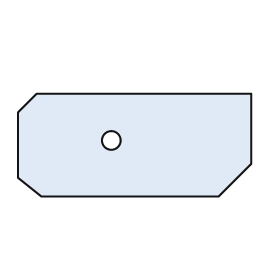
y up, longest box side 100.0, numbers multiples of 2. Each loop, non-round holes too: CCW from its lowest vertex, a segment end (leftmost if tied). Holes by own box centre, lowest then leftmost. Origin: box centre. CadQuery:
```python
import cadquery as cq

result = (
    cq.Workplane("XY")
    .moveTo(-40.0, -22.0)
    .lineTo(36.0, -22.0)
    .lineTo(50.0, -8.0)
    .lineTo(50.0, 22.0)
    .lineTo(-42.0, 22.0)
    .lineTo(-50.0, 14.0)
    .lineTo(-50.0, -14.0)
    .close()
    .moveTo(-10.0, 2.0)
    .circle(4.0)
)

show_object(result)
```